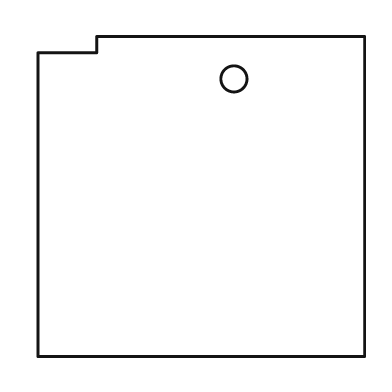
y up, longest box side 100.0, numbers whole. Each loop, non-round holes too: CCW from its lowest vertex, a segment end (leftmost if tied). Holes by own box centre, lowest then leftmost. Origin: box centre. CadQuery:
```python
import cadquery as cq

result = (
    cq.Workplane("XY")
    .moveTo(-50.0, -49.0)
    .lineTo(50.0, -49.0)
    .lineTo(50.0, 49.0)
    .lineTo(-32.0, 49.0)
    .lineTo(-32.0, 44.0)
    .lineTo(-50.0, 44.0)
    .close()
    .moveTo(10.0, 36.0)
    .circle(4.0)
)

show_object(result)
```